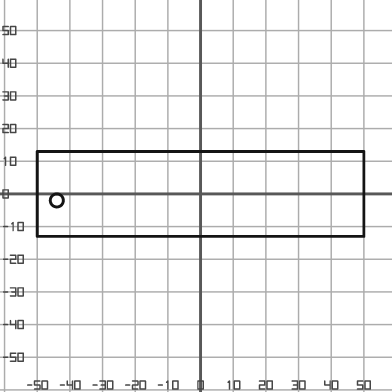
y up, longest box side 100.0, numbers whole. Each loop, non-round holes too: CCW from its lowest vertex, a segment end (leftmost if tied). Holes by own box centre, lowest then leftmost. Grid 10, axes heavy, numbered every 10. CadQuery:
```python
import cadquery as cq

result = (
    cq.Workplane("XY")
    .moveTo(-50.0, -13.0)
    .lineTo(50.0, -13.0)
    .lineTo(50.0, 13.0)
    .lineTo(-50.0, 13.0)
    .close()
    .moveTo(-44.0, -2.0)
    .circle(2.0)
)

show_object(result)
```